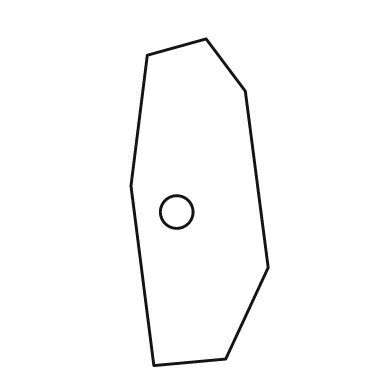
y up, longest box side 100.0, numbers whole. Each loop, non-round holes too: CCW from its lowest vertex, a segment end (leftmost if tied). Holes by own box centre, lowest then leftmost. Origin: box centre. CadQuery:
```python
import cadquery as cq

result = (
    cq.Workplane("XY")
    .moveTo(-14.0, -50.0)
    .lineTo(8.0, -48.0)
    .lineTo(21.0, -20.0)
    .lineTo(14.0, 34.0)
    .lineTo(2.0, 50.0)
    .lineTo(-16.0, 45.0)
    .lineTo(-21.0, 5.0)
    .close()
    .moveTo(-7.0, -3.0)
    .circle(5.0)
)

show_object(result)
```